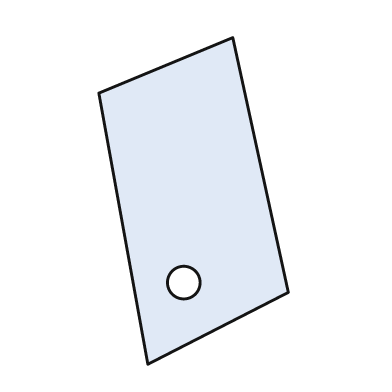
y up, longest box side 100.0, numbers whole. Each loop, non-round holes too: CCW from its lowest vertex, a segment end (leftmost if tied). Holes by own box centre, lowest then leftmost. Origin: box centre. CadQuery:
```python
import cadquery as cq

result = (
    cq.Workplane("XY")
    .moveTo(-14.0, -50.0)
    .lineTo(29.0, -28.0)
    .lineTo(12.0, 50.0)
    .lineTo(-29.0, 33.0)
    .close()
    .moveTo(-3.0, -25.0)
    .circle(5.0)
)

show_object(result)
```